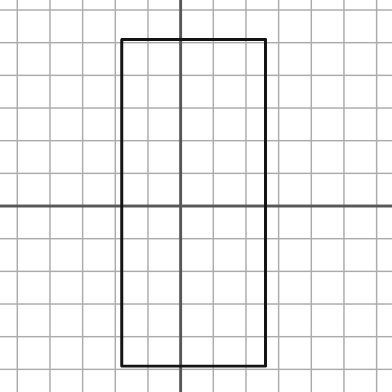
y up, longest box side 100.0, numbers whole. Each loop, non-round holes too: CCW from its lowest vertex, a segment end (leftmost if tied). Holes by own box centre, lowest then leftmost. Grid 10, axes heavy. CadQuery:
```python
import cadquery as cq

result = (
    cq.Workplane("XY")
    .moveTo(-18.0, -49.0)
    .lineTo(26.0, -49.0)
    .lineTo(26.0, 51.0)
    .lineTo(-18.0, 51.0)
    .close()
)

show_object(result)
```